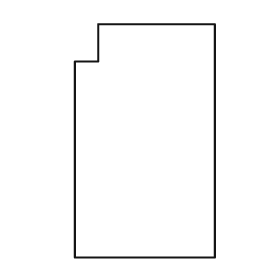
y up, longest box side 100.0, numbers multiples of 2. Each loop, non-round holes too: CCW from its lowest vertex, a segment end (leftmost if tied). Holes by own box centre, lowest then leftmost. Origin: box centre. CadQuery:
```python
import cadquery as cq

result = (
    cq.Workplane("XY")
    .moveTo(-30.0, -50.0)
    .lineTo(30.0, -50.0)
    .lineTo(30.0, 50.0)
    .lineTo(-20.0, 50.0)
    .lineTo(-20.0, 34.0)
    .lineTo(-30.0, 34.0)
    .close()
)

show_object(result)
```